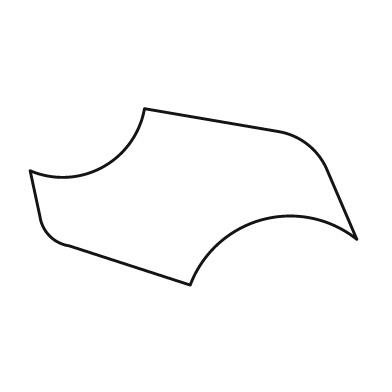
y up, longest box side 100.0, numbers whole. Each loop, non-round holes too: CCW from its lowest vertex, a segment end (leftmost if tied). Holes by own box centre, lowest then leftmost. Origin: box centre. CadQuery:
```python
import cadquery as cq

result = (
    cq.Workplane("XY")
    .moveTo(-1.0, -27.0)
    .threePointArc((21.0, -7.0), (50.0, -13.0))
    .lineTo(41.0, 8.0)
    .threePointArc((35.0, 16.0), (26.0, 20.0))
    .lineTo(-15.0, 27.0)
    .threePointArc((-28.0, 9.0), (-50.0, 8.0))
    .lineTo(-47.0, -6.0)
    .threePointArc((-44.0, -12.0), (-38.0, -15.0))
    .close()
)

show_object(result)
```